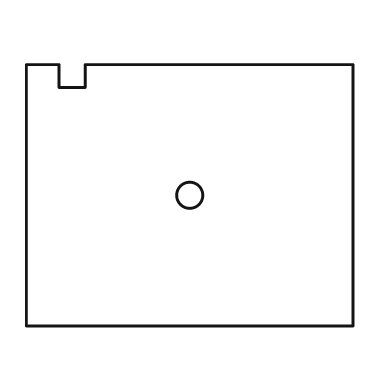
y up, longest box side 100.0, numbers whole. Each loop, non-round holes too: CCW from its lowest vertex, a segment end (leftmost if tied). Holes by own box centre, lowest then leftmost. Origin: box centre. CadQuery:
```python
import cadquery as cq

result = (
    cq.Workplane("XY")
    .moveTo(-50.0, -40.0)
    .lineTo(50.0, -40.0)
    .lineTo(50.0, 40.0)
    .lineTo(-32.0, 40.0)
    .lineTo(-32.0, 33.0)
    .lineTo(-40.0, 33.0)
    .lineTo(-40.0, 40.0)
    .lineTo(-50.0, 40.0)
    .close()
    .moveTo(0.0, 0.0)
    .circle(4.0)
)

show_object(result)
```